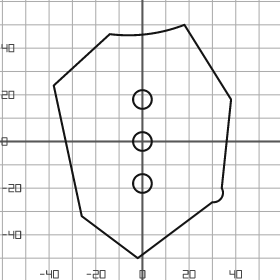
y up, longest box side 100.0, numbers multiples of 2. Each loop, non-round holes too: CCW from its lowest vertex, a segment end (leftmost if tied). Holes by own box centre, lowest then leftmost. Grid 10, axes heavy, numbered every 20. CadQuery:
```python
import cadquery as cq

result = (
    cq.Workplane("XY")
    .moveTo(-2.0, -50.0)
    .lineTo(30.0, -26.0)
    .threePointArc((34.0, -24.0), (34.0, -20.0))
    .lineTo(38.0, 18.0)
    .lineTo(18.0, 50.0)
    .threePointArc((2.0, 46.0), (-14.0, 46.0))
    .lineTo(-38.0, 24.0)
    .lineTo(-26.0, -32.0)
    .close()
    .moveTo(0.0, -18.0)
    .circle(4.0)
    .moveTo(0.0, 0.0)
    .circle(4.0)
    .moveTo(0.0, 18.0)
    .circle(4.0)
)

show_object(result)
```